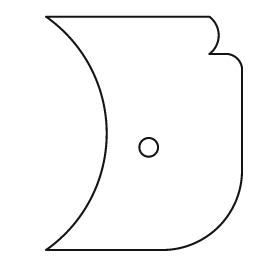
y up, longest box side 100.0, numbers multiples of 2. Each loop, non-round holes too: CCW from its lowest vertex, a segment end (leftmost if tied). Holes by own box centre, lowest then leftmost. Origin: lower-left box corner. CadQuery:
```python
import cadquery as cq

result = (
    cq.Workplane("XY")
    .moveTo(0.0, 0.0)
    .lineTo(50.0, 0.0)
    .threePointArc((74.0, 10.0), (84.0, 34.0))
    .lineTo(84.0, 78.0)
    .threePointArc((82.0, 82.0), (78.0, 84.0))
    .lineTo(70.0, 84.0)
    .threePointArc((74.0, 92.0), (70.0, 100.0))
    .lineTo(0.0, 100.0)
    .threePointArc((26.0, 50.0), (0.0, 0.0))
    .close()
    .moveTo(44.0, 44.0)
    .circle(4.0)
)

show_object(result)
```